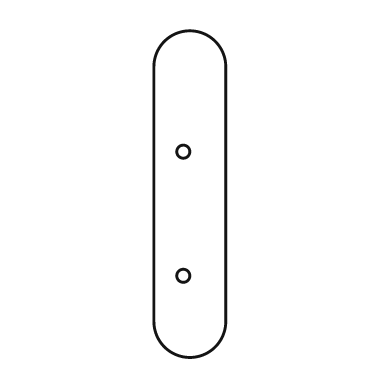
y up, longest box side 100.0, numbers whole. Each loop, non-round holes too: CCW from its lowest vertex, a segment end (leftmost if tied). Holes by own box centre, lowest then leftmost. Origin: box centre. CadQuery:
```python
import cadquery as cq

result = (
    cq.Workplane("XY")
    .moveTo(-11.0, -39.0)
    .threePointArc((0.0, -50.0), (11.0, -39.0))
    .lineTo(11.0, 39.0)
    .threePointArc((0.0, 50.0), (-11.0, 39.0))
    .close()
    .moveTo(-2.0, -25.0)
    .circle(2.0)
    .moveTo(-2.0, 13.0)
    .circle(2.0)
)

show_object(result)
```